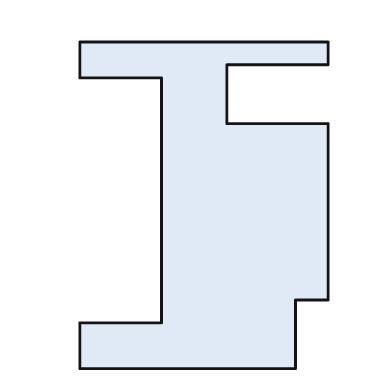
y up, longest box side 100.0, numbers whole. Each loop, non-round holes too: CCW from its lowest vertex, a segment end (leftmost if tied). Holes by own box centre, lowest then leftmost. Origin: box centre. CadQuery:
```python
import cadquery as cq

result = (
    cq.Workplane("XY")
    .moveTo(-38.0, -50.0)
    .lineTo(28.0, -50.0)
    .lineTo(28.0, -29.0)
    .lineTo(38.0, -29.0)
    .lineTo(38.0, 25.0)
    .lineTo(7.0, 25.0)
    .lineTo(7.0, 43.0)
    .lineTo(38.0, 43.0)
    .lineTo(38.0, 50.0)
    .lineTo(-38.0, 50.0)
    .lineTo(-38.0, 39.0)
    .lineTo(-13.0, 39.0)
    .lineTo(-13.0, -36.0)
    .lineTo(-38.0, -36.0)
    .close()
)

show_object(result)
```